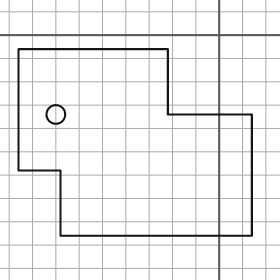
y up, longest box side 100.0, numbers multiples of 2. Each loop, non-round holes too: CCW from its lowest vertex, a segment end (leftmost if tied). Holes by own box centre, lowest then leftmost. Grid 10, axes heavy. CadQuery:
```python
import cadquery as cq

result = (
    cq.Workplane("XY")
    .moveTo(-68.0, -86.0)
    .lineTo(14.0, -86.0)
    .lineTo(14.0, -34.0)
    .lineTo(-22.0, -34.0)
    .lineTo(-22.0, -6.0)
    .lineTo(-86.0, -6.0)
    .lineTo(-86.0, -58.0)
    .lineTo(-68.0, -58.0)
    .close()
    .moveTo(-70.0, -34.0)
    .circle(4.0)
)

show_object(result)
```